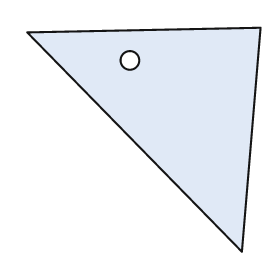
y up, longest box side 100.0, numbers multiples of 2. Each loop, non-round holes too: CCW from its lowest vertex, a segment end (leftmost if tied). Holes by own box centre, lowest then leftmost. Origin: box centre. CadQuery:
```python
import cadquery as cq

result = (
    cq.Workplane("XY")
    .moveTo(42.0, -48.0)
    .lineTo(50.0, 48.0)
    .lineTo(-50.0, 46.0)
    .close()
    .moveTo(-6.0, 34.0)
    .circle(4.0)
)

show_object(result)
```